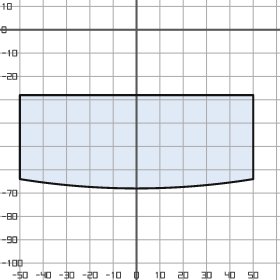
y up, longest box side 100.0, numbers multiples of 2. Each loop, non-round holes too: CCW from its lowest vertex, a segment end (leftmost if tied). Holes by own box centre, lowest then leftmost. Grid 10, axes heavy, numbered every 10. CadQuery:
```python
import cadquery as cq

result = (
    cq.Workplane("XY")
    .moveTo(-50.0, -64.0)
    .threePointArc((0.0, -68.0), (50.0, -64.0))
    .lineTo(50.0, -28.0)
    .lineTo(-50.0, -28.0)
    .close()
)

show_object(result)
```